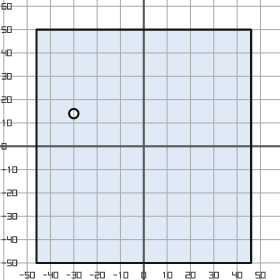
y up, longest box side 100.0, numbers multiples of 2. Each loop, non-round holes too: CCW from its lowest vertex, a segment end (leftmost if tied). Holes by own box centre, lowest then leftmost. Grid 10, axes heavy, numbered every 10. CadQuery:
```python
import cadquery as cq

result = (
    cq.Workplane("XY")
    .moveTo(-46.0, -50.0)
    .lineTo(46.0, -50.0)
    .lineTo(46.0, 50.0)
    .lineTo(-46.0, 50.0)
    .close()
    .moveTo(-30.0, 14.0)
    .circle(2.0)
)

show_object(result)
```